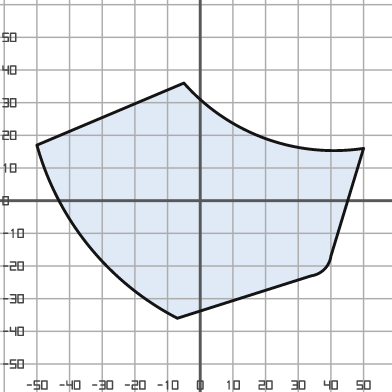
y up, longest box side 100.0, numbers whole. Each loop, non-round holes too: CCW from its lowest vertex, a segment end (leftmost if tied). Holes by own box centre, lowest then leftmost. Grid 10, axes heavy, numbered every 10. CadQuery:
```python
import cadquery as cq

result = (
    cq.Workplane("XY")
    .moveTo(-7.0, -36.0)
    .lineTo(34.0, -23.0)
    .threePointArc((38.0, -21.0), (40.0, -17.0))
    .lineTo(50.0, 16.0)
    .threePointArc((20.0, 19.0), (-5.0, 36.0))
    .lineTo(-50.0, 17.0)
    .threePointArc((-34.0, -14.0), (-7.0, -36.0))
    .close()
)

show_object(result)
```